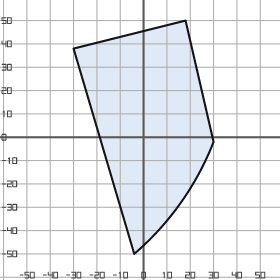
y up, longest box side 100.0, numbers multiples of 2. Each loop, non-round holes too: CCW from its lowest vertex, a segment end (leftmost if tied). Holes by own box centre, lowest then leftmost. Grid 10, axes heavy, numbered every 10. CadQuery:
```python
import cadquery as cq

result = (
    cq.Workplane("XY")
    .moveTo(-4.0, -50.0)
    .threePointArc((16.0, -28.0), (30.0, -2.0))
    .lineTo(18.0, 50.0)
    .lineTo(-30.0, 38.0)
    .close()
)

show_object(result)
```